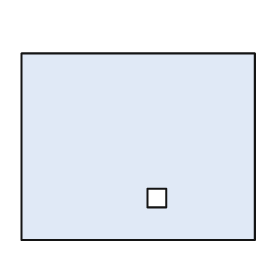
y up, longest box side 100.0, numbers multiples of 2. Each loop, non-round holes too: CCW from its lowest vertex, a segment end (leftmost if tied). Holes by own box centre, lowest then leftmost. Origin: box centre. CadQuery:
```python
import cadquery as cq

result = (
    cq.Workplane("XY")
    .moveTo(-50.0, -40.0)
    .lineTo(50.0, -40.0)
    .lineTo(50.0, 40.0)
    .lineTo(-50.0, 40.0)
    .close()
    .moveTo(4.0, -26.0)
    .lineTo(12.0, -26.0)
    .lineTo(12.0, -18.0)
    .lineTo(4.0, -18.0)
    .close()
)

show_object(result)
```